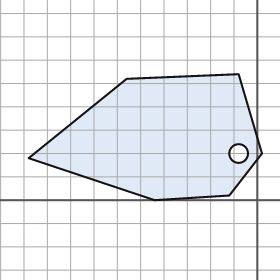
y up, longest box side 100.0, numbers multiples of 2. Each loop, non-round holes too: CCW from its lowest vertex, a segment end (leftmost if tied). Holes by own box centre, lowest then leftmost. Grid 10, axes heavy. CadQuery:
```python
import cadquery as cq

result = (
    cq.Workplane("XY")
    .moveTo(-44.0, 0.0)
    .lineTo(-12.0, 2.0)
    .lineTo(2.0, 20.0)
    .lineTo(-8.0, 54.0)
    .lineTo(-56.0, 52.0)
    .lineTo(-98.0, 18.0)
    .close()
    .moveTo(-8.0, 20.0)
    .circle(4.0)
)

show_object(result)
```